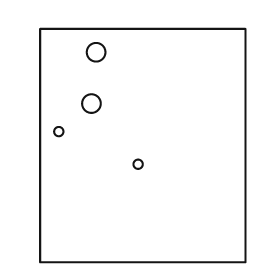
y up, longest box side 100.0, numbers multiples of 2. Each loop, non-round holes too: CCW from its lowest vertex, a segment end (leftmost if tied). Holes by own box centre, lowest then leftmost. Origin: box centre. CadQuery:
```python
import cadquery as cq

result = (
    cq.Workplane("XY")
    .moveTo(-44.0, -50.0)
    .lineTo(44.0, -50.0)
    .lineTo(44.0, 50.0)
    .lineTo(-44.0, 50.0)
    .close()
    .moveTo(-2.0, -8.0)
    .circle(2.0)
    .moveTo(-36.0, 6.0)
    .circle(2.0)
    .moveTo(-22.0, 18.0)
    .circle(4.0)
    .moveTo(-20.0, 40.0)
    .circle(4.0)
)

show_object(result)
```